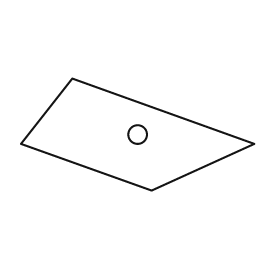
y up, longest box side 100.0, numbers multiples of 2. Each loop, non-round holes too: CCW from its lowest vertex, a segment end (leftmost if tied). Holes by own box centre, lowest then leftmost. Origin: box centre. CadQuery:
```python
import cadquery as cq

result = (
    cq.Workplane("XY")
    .moveTo(6.0, -24.0)
    .lineTo(50.0, -4.0)
    .lineTo(-28.0, 24.0)
    .lineTo(-50.0, -4.0)
    .close()
    .moveTo(0.0, 0.0)
    .circle(4.0)
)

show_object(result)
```